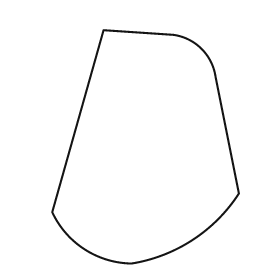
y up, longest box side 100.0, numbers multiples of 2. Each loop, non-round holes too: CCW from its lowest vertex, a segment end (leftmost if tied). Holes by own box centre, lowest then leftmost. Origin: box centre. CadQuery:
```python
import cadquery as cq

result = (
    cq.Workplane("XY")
    .moveTo(-6.0, -50.0)
    .threePointArc((20.0, -40.0), (40.0, -20.0))
    .lineTo(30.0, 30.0)
    .threePointArc((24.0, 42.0), (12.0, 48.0))
    .lineTo(-18.0, 50.0)
    .lineTo(-40.0, -28.0)
    .threePointArc((-26.0, -44.0), (-6.0, -50.0))
    .close()
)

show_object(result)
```